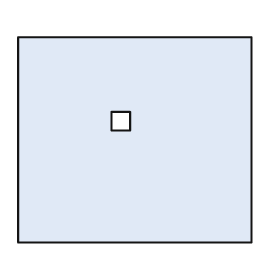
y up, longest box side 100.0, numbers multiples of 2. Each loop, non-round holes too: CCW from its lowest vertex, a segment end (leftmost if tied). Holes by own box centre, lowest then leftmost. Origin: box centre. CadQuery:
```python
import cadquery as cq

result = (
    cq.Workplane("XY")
    .moveTo(-50.0, -44.0)
    .lineTo(50.0, -44.0)
    .lineTo(50.0, 44.0)
    .lineTo(-50.0, 44.0)
    .close()
    .moveTo(-10.0, 4.0)
    .lineTo(-2.0, 4.0)
    .lineTo(-2.0, 12.0)
    .lineTo(-10.0, 12.0)
    .close()
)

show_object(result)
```